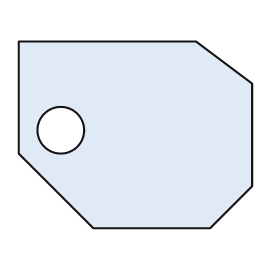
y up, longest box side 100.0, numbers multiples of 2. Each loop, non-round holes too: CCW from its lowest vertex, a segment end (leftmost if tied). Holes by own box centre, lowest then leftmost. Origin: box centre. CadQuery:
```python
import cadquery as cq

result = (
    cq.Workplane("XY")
    .moveTo(-18.0, -40.0)
    .lineTo(32.0, -40.0)
    .lineTo(50.0, -22.0)
    .lineTo(50.0, 22.0)
    .lineTo(26.0, 40.0)
    .lineTo(-50.0, 40.0)
    .lineTo(-50.0, -8.0)
    .close()
    .moveTo(-32.0, 2.0)
    .circle(10.0)
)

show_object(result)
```